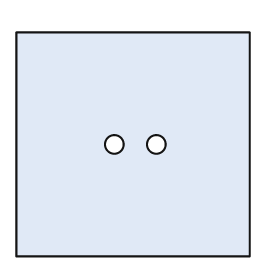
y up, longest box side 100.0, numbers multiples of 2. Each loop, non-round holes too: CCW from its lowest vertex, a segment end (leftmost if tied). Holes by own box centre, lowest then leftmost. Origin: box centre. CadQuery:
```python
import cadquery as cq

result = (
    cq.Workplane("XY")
    .moveTo(-50.0, -48.0)
    .lineTo(50.0, -48.0)
    .lineTo(50.0, 48.0)
    .lineTo(-50.0, 48.0)
    .close()
    .moveTo(-8.0, 0.0)
    .circle(4.0)
    .moveTo(10.0, 0.0)
    .circle(4.0)
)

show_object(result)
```